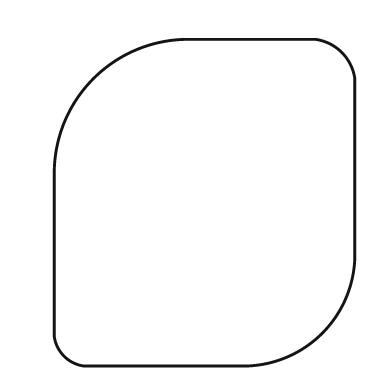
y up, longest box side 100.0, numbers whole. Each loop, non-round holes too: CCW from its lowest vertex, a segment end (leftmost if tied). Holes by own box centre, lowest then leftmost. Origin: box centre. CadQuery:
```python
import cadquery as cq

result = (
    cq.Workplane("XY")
    .moveTo(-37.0, -50.0)
    .lineTo(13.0, -50.0)
    .threePointArc((36.0, -40.0), (46.0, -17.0))
    .lineTo(46.0, 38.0)
    .threePointArc((42.0, 46.0), (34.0, 50.0))
    .lineTo(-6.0, 50.0)
    .threePointArc((-34.0, 38.0), (-46.0, 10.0))
    .lineTo(-46.0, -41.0)
    .threePointArc((-43.0, -47.0), (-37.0, -50.0))
    .close()
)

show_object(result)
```